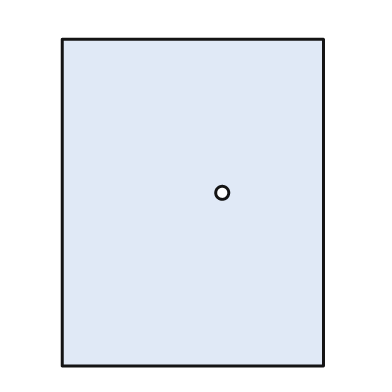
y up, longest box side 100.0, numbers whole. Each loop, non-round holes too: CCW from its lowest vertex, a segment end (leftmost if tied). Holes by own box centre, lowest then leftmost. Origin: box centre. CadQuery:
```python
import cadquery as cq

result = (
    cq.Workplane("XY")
    .moveTo(-40.0, -50.0)
    .lineTo(40.0, -50.0)
    .lineTo(40.0, 50.0)
    .lineTo(-40.0, 50.0)
    .close()
    .moveTo(9.0, 3.0)
    .circle(2.0)
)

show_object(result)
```